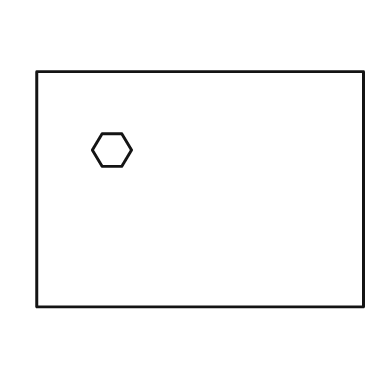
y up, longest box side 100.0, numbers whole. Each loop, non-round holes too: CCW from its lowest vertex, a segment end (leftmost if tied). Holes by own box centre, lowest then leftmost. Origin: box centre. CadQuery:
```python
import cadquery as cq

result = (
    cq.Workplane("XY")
    .moveTo(-50.0, -36.0)
    .lineTo(50.0, -36.0)
    .lineTo(50.0, 36.0)
    .lineTo(-50.0, 36.0)
    .close()
    .moveTo(-30.0, 7.0)
    .lineTo(-24.0, 7.0)
    .lineTo(-21.0, 12.0)
    .lineTo(-24.0, 17.0)
    .lineTo(-30.0, 17.0)
    .lineTo(-33.0, 12.0)
    .close()
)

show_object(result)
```